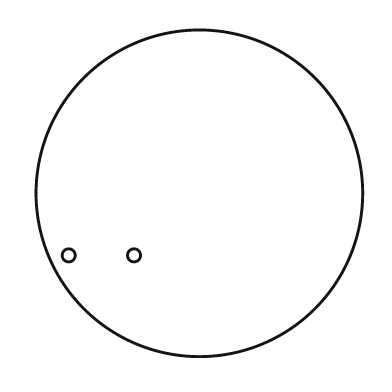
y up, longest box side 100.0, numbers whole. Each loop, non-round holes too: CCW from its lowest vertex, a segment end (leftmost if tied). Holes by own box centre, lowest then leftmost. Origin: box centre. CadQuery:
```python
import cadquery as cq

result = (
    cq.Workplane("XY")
    .moveTo(0.0, 0.0)
    .circle(50.0)
    .moveTo(-40.0, -19.0)
    .circle(2.0)
    .moveTo(-20.0, -19.0)
    .circle(2.0)
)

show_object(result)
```